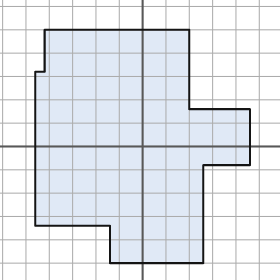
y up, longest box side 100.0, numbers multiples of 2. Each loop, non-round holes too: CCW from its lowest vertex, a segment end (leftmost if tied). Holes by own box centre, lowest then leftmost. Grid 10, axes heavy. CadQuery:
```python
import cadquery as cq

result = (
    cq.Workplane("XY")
    .moveTo(-14.0, -50.0)
    .lineTo(26.0, -50.0)
    .lineTo(26.0, -8.0)
    .lineTo(46.0, -8.0)
    .lineTo(46.0, 16.0)
    .lineTo(20.0, 16.0)
    .lineTo(20.0, 50.0)
    .lineTo(-42.0, 50.0)
    .lineTo(-42.0, 32.0)
    .lineTo(-46.0, 32.0)
    .lineTo(-46.0, -34.0)
    .lineTo(-14.0, -34.0)
    .close()
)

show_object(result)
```